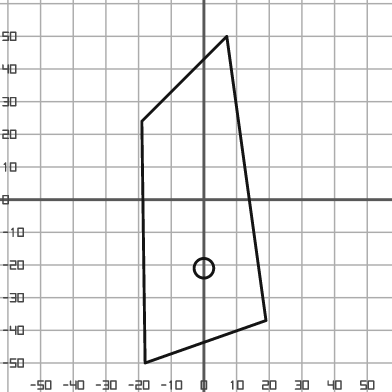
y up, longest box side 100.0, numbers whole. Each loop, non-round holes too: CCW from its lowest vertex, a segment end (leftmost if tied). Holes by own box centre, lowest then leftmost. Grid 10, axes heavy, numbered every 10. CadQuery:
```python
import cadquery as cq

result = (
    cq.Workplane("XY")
    .moveTo(-18.0, -50.0)
    .lineTo(19.0, -37.0)
    .lineTo(7.0, 50.0)
    .lineTo(-19.0, 24.0)
    .close()
    .moveTo(0.0, -21.0)
    .circle(3.0)
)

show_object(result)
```